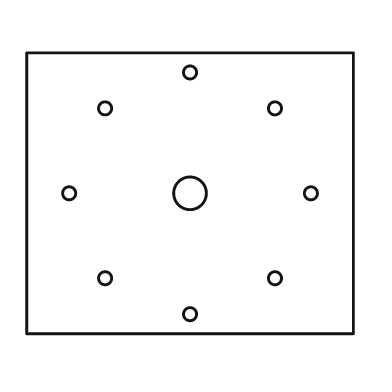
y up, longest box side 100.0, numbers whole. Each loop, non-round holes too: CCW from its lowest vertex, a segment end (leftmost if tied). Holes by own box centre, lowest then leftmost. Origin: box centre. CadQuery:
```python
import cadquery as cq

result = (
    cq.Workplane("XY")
    .moveTo(-50.0, -43.0)
    .lineTo(50.0, -43.0)
    .lineTo(50.0, 43.0)
    .lineTo(-50.0, 43.0)
    .close()
    .moveTo(0.0, -37.0)
    .circle(2.0)
    .moveTo(-26.0, -26.0)
    .circle(2.0)
    .moveTo(26.0, -26.0)
    .circle(2.0)
    .moveTo(-37.0, 0.0)
    .circle(2.0)
    .moveTo(0.0, 0.0)
    .circle(5.0)
    .moveTo(37.0, 0.0)
    .circle(2.0)
    .moveTo(-26.0, 26.0)
    .circle(2.0)
    .moveTo(26.0, 26.0)
    .circle(2.0)
    .moveTo(0.0, 37.0)
    .circle(2.0)
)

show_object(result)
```